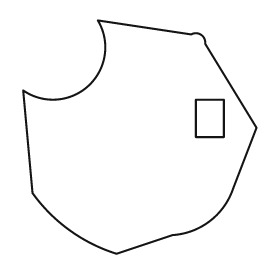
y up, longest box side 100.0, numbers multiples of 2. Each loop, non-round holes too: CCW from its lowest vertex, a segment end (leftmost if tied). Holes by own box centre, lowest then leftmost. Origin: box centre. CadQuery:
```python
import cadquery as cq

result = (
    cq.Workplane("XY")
    .moveTo(-10.0, -50.0)
    .lineTo(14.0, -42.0)
    .threePointArc((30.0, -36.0), (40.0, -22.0))
    .lineTo(50.0, 4.0)
    .lineTo(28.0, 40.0)
    .threePointArc((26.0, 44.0), (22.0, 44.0))
    .lineTo(-18.0, 50.0)
    .threePointArc((-22.0, 22.0), (-50.0, 20.0))
    .lineTo(-46.0, -24.0)
    .threePointArc((-30.0, -40.0), (-10.0, -50.0))
    .close()
    .moveTo(24.0, 0.0)
    .lineTo(36.0, 0.0)
    .lineTo(36.0, 16.0)
    .lineTo(24.0, 16.0)
    .close()
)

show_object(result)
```